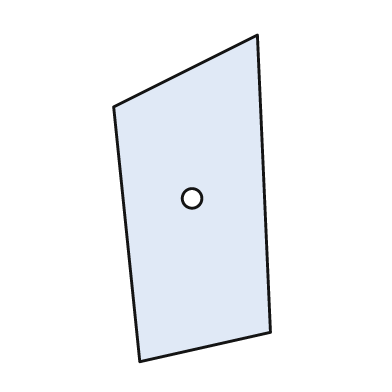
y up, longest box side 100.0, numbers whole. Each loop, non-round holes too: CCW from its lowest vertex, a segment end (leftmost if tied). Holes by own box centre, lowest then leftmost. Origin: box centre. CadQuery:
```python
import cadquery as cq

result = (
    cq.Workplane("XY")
    .moveTo(-16.0, -50.0)
    .lineTo(24.0, -41.0)
    .lineTo(20.0, 50.0)
    .lineTo(-24.0, 28.0)
    .close()
    .moveTo(0.0, 0.0)
    .circle(3.0)
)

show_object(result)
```